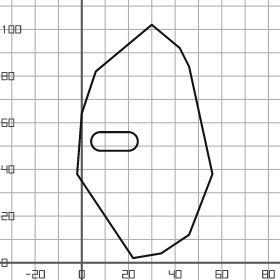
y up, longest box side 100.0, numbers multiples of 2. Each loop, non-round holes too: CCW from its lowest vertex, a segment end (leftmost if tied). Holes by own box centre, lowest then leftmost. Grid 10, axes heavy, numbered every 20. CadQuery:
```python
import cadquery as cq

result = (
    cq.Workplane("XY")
    .moveTo(22.0, 2.0)
    .lineTo(34.0, 4.0)
    .lineTo(46.0, 12.0)
    .lineTo(56.0, 38.0)
    .lineTo(46.0, 84.0)
    .lineTo(42.0, 92.0)
    .lineTo(30.0, 102.0)
    .lineTo(6.0, 82.0)
    .lineTo(0.0, 64.0)
    .lineTo(-2.0, 38.0)
    .close()
    .moveTo(8.0, 48.0)
    .lineTo(20.0, 48.0)
    .threePointArc((24.0, 52.0), (20.0, 56.0))
    .lineTo(8.0, 56.0)
    .threePointArc((4.0, 52.0), (8.0, 48.0))
    .close()
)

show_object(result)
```